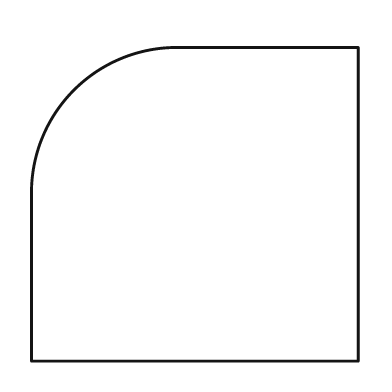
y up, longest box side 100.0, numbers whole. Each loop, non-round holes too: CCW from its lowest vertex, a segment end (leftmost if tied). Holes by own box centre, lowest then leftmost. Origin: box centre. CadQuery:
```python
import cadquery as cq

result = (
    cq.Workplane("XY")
    .moveTo(-50.0, -48.0)
    .lineTo(50.0, -48.0)
    .lineTo(50.0, 48.0)
    .lineTo(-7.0, 48.0)
    .threePointArc((-37.0, 35.0), (-50.0, 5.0))
    .close()
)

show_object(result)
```